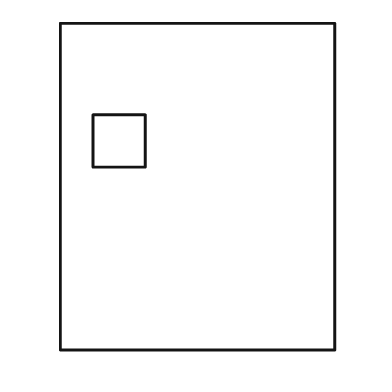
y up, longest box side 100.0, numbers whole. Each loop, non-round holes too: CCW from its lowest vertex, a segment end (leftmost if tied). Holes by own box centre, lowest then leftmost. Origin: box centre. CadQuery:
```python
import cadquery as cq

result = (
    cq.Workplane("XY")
    .moveTo(-42.0, -50.0)
    .lineTo(42.0, -50.0)
    .lineTo(42.0, 50.0)
    .lineTo(-42.0, 50.0)
    .close()
    .moveTo(-32.0, 6.0)
    .lineTo(-16.0, 6.0)
    .lineTo(-16.0, 22.0)
    .lineTo(-32.0, 22.0)
    .close()
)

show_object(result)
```